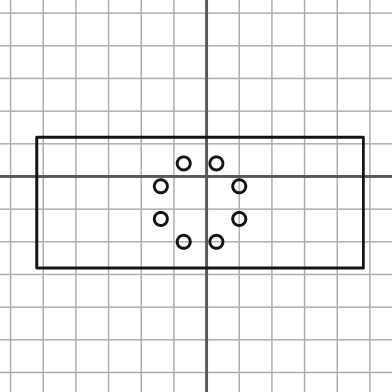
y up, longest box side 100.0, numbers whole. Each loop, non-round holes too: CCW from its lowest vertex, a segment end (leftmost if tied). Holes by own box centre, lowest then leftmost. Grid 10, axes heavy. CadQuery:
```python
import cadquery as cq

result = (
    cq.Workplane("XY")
    .moveTo(-52.0, -28.0)
    .lineTo(48.0, -28.0)
    .lineTo(48.0, 12.0)
    .lineTo(-52.0, 12.0)
    .close()
    .moveTo(-7.0, -20.0)
    .circle(2.0)
    .moveTo(3.0, -20.0)
    .circle(2.0)
    .moveTo(-14.0, -13.0)
    .circle(2.0)
    .moveTo(10.0, -13.0)
    .circle(2.0)
    .moveTo(-14.0, -3.0)
    .circle(2.0)
    .moveTo(10.0, -3.0)
    .circle(2.0)
    .moveTo(-7.0, 4.0)
    .circle(2.0)
    .moveTo(3.0, 4.0)
    .circle(2.0)
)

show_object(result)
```